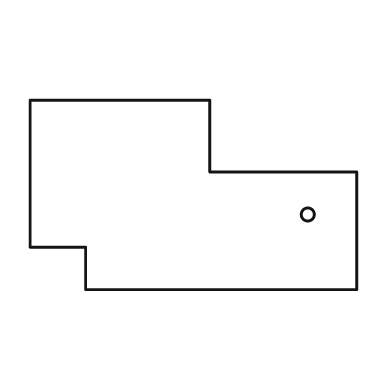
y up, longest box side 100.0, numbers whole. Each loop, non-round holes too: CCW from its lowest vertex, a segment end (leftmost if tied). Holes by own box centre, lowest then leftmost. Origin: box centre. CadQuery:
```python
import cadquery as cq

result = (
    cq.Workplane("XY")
    .moveTo(-33.0, -29.0)
    .lineTo(50.0, -29.0)
    .lineTo(50.0, 7.0)
    .lineTo(5.0, 7.0)
    .lineTo(5.0, 29.0)
    .lineTo(-50.0, 29.0)
    .lineTo(-50.0, -16.0)
    .lineTo(-33.0, -16.0)
    .close()
    .moveTo(35.0, -6.0)
    .circle(2.0)
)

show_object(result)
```